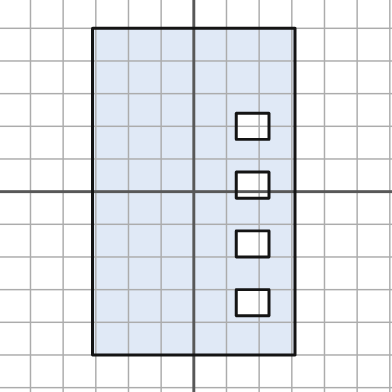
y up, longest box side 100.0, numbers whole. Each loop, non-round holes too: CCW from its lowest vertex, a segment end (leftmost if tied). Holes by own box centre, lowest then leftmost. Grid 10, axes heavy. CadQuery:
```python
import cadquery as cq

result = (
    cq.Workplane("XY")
    .moveTo(-31.0, -50.0)
    .lineTo(31.0, -50.0)
    .lineTo(31.0, 50.0)
    .lineTo(-31.0, 50.0)
    .close()
    .moveTo(13.0, -38.0)
    .lineTo(23.0, -38.0)
    .lineTo(23.0, -30.0)
    .lineTo(13.0, -30.0)
    .close()
    .moveTo(13.0, -20.0)
    .lineTo(23.0, -20.0)
    .lineTo(23.0, -12.0)
    .lineTo(13.0, -12.0)
    .close()
    .moveTo(13.0, -2.0)
    .lineTo(23.0, -2.0)
    .lineTo(23.0, 6.0)
    .lineTo(13.0, 6.0)
    .close()
    .moveTo(13.0, 16.0)
    .lineTo(23.0, 16.0)
    .lineTo(23.0, 24.0)
    .lineTo(13.0, 24.0)
    .close()
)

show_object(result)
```